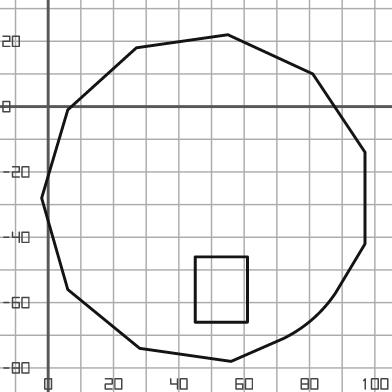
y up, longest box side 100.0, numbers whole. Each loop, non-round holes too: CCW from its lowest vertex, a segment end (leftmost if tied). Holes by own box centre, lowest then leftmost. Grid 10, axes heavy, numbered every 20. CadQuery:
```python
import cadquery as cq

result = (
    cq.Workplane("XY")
    .moveTo(56.0, -78.0)
    .lineTo(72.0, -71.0)
    .threePointArc((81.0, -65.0), (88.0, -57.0))
    .lineTo(97.0, -42.0)
    .lineTo(97.0, -14.0)
    .lineTo(81.0, 10.0)
    .lineTo(55.0, 22.0)
    .lineTo(27.0, 18.0)
    .lineTo(6.0, -1.0)
    .lineTo(-2.0, -28.0)
    .lineTo(6.0, -56.0)
    .lineTo(28.0, -74.0)
    .close()
    .moveTo(45.0, -66.0)
    .lineTo(61.0, -66.0)
    .lineTo(61.0, -46.0)
    .lineTo(45.0, -46.0)
    .close()
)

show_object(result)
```